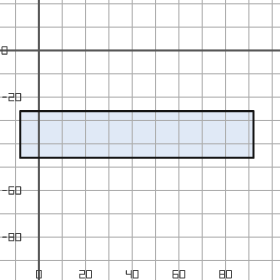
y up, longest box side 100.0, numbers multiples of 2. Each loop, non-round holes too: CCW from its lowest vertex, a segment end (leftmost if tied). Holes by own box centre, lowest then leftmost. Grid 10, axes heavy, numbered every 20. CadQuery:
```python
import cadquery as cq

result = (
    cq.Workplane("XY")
    .moveTo(-8.0, -46.0)
    .lineTo(92.0, -46.0)
    .lineTo(92.0, -26.0)
    .lineTo(-8.0, -26.0)
    .close()
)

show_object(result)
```